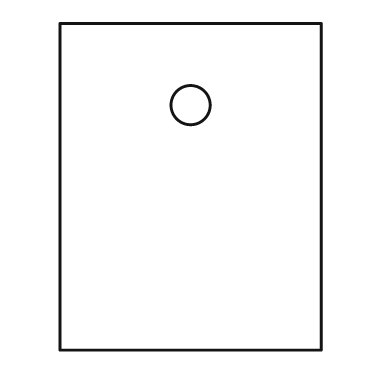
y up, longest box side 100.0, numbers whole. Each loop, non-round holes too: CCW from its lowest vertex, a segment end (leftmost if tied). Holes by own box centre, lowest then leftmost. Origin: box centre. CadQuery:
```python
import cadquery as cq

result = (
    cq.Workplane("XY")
    .moveTo(-40.0, -50.0)
    .lineTo(40.0, -50.0)
    .lineTo(40.0, 50.0)
    .lineTo(-40.0, 50.0)
    .close()
    .moveTo(0.0, 25.0)
    .circle(6.0)
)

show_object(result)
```